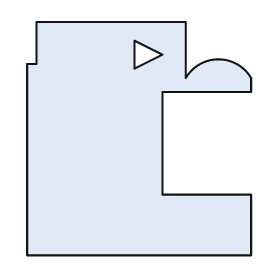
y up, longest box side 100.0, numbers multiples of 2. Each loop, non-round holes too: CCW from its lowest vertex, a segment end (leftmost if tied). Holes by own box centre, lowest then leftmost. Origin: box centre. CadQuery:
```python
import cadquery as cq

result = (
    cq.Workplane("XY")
    .moveTo(-48.0, -50.0)
    .lineTo(48.0, -50.0)
    .lineTo(48.0, -24.0)
    .lineTo(10.0, -24.0)
    .lineTo(10.0, 20.0)
    .lineTo(48.0, 20.0)
    .lineTo(48.0, 26.0)
    .threePointArc((34.0, 34.0), (20.0, 26.0))
    .lineTo(20.0, 50.0)
    .lineTo(-44.0, 50.0)
    .lineTo(-44.0, 32.0)
    .lineTo(-48.0, 32.0)
    .close()
    .moveTo(-2.0, 30.0)
    .lineTo(10.0, 36.0)
    .lineTo(-2.0, 42.0)
    .close()
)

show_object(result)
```